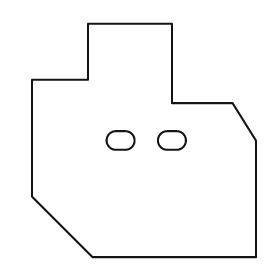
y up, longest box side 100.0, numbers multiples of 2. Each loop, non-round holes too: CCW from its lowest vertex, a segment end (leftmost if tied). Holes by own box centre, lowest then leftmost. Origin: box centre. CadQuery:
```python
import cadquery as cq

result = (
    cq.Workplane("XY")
    .moveTo(-22.0, -50.0)
    .lineTo(48.0, -50.0)
    .lineTo(48.0, 0.0)
    .lineTo(38.0, 16.0)
    .lineTo(12.0, 16.0)
    .lineTo(12.0, 50.0)
    .lineTo(-24.0, 50.0)
    .lineTo(-24.0, 26.0)
    .lineTo(-48.0, 26.0)
    .lineTo(-48.0, -24.0)
    .close()
    .moveTo(-12.0, -4.0)
    .lineTo(-8.0, -4.0)
    .threePointArc((-4.0, 0.0), (-8.0, 4.0))
    .lineTo(-12.0, 4.0)
    .threePointArc((-16.0, 0.0), (-12.0, -4.0))
    .close()
    .moveTo(10.0, -4.0)
    .lineTo(14.0, -4.0)
    .threePointArc((18.0, 0.0), (14.0, 4.0))
    .lineTo(10.0, 4.0)
    .threePointArc((6.0, 0.0), (10.0, -4.0))
    .close()
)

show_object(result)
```